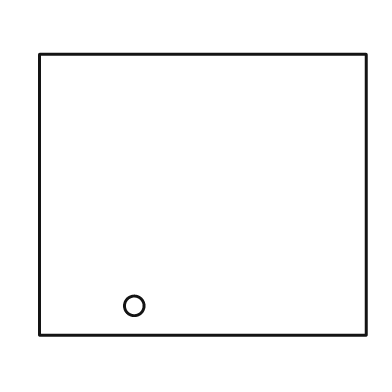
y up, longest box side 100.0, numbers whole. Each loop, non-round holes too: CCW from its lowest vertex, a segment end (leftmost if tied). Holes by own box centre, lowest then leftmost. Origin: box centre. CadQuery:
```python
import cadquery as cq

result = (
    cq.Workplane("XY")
    .moveTo(-50.0, -43.0)
    .lineTo(50.0, -43.0)
    .lineTo(50.0, 43.0)
    .lineTo(-50.0, 43.0)
    .close()
    .moveTo(-21.0, -34.0)
    .circle(3.0)
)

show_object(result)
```